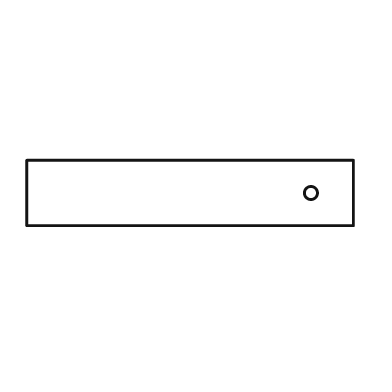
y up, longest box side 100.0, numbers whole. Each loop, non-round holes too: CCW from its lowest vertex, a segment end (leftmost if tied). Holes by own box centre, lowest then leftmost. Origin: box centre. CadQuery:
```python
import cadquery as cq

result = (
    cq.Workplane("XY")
    .moveTo(-50.0, -10.0)
    .lineTo(50.0, -10.0)
    .lineTo(50.0, 10.0)
    .lineTo(-50.0, 10.0)
    .close()
    .moveTo(37.0, 0.0)
    .circle(2.0)
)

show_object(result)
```